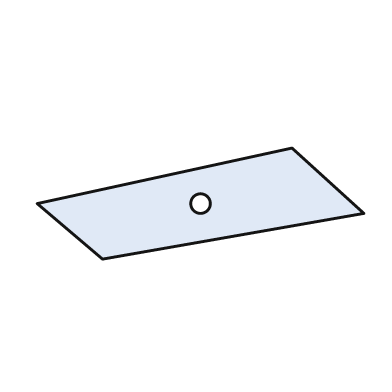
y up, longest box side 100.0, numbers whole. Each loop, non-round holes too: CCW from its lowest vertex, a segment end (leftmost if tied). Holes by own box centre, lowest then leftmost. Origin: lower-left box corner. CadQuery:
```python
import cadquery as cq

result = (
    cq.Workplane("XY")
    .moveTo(20.0, 0.0)
    .lineTo(100.0, 14.0)
    .lineTo(78.0, 34.0)
    .lineTo(0.0, 17.0)
    .close()
    .moveTo(50.0, 17.0)
    .circle(3.0)
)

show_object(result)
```